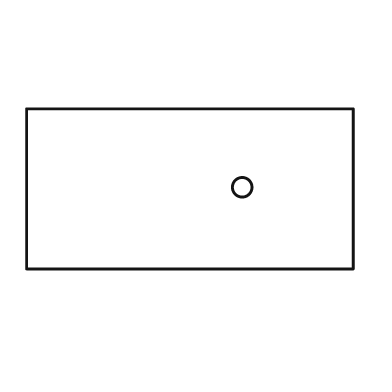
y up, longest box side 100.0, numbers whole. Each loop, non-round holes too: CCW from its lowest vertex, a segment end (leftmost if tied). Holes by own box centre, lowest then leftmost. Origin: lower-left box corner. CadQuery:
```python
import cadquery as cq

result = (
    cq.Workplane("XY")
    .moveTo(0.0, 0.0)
    .lineTo(100.0, 0.0)
    .lineTo(100.0, 49.0)
    .lineTo(0.0, 49.0)
    .close()
    .moveTo(66.0, 25.0)
    .circle(3.0)
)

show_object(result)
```